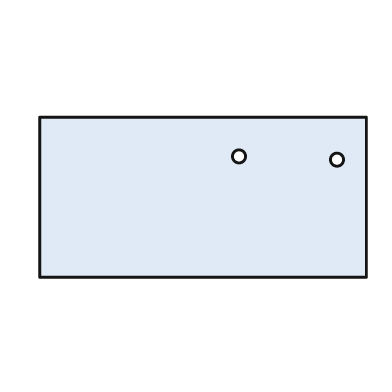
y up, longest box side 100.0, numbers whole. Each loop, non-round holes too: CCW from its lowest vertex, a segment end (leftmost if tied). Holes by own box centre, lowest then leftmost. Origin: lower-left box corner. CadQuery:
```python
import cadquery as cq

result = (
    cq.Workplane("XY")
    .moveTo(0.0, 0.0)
    .lineTo(100.0, 0.0)
    .lineTo(100.0, 49.0)
    .lineTo(0.0, 49.0)
    .close()
    .moveTo(91.0, 36.0)
    .circle(2.0)
    .moveTo(61.0, 37.0)
    .circle(2.0)
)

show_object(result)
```